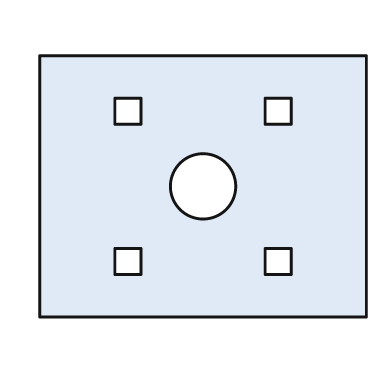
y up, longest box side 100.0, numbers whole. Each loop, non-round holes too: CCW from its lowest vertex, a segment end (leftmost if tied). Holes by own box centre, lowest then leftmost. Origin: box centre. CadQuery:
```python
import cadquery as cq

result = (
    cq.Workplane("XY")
    .moveTo(-50.0, -40.0)
    .lineTo(50.0, -40.0)
    .lineTo(50.0, 40.0)
    .lineTo(-50.0, 40.0)
    .close()
    .moveTo(-27.0, -27.0)
    .lineTo(-19.0, -27.0)
    .lineTo(-19.0, -19.0)
    .lineTo(-27.0, -19.0)
    .close()
    .moveTo(19.0, -27.0)
    .lineTo(27.0, -27.0)
    .lineTo(27.0, -19.0)
    .lineTo(19.0, -19.0)
    .close()
    .moveTo(0.0, 0.0)
    .circle(10.0)
    .moveTo(-27.0, 19.0)
    .lineTo(-19.0, 19.0)
    .lineTo(-19.0, 27.0)
    .lineTo(-27.0, 27.0)
    .close()
    .moveTo(19.0, 19.0)
    .lineTo(27.0, 19.0)
    .lineTo(27.0, 27.0)
    .lineTo(19.0, 27.0)
    .close()
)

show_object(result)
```